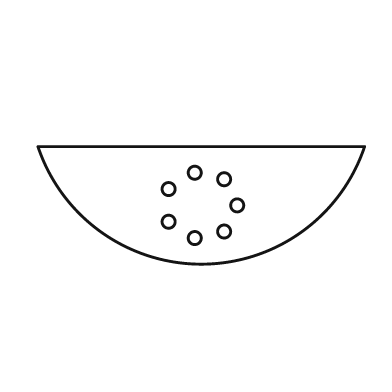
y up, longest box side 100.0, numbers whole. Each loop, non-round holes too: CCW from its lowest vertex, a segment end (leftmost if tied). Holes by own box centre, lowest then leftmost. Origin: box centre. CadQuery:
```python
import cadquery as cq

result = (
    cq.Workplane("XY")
    .moveTo(-50.0, 18.0)
    .threePointArc((0.0, -18.0), (50.0, 18.0))
    .close()
    .moveTo(-2.0, -10.0)
    .circle(2.0)
    .moveTo(7.0, -8.0)
    .circle(2.0)
    .moveTo(-10.0, -5.0)
    .circle(2.0)
    .moveTo(11.0, 0.0)
    .circle(2.0)
    .moveTo(-10.0, 5.0)
    .circle(2.0)
    .moveTo(7.0, 8.0)
    .circle(2.0)
    .moveTo(-2.0, 10.0)
    .circle(2.0)
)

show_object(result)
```